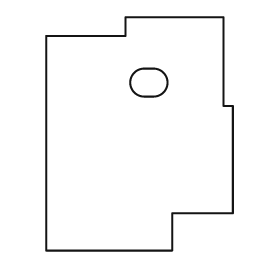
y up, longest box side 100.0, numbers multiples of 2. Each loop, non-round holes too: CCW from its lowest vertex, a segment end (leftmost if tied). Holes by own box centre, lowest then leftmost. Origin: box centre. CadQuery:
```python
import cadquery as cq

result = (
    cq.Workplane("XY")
    .moveTo(-40.0, -50.0)
    .lineTo(14.0, -50.0)
    .lineTo(14.0, -34.0)
    .lineTo(40.0, -34.0)
    .lineTo(40.0, 12.0)
    .lineTo(36.0, 12.0)
    .lineTo(36.0, 50.0)
    .lineTo(-6.0, 50.0)
    .lineTo(-6.0, 42.0)
    .lineTo(-40.0, 42.0)
    .close()
    .moveTo(2.0, 16.0)
    .lineTo(6.0, 16.0)
    .threePointArc((12.0, 22.0), (6.0, 28.0))
    .lineTo(2.0, 28.0)
    .threePointArc((-4.0, 22.0), (2.0, 16.0))
    .close()
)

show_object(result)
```